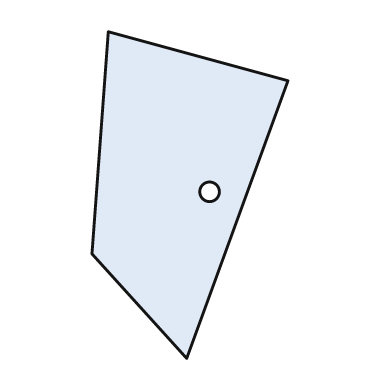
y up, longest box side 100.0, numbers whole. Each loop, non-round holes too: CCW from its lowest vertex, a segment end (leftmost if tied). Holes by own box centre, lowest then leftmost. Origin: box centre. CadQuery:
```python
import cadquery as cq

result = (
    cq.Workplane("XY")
    .moveTo(-1.0, -50.0)
    .lineTo(30.0, 35.0)
    .lineTo(-25.0, 50.0)
    .lineTo(-30.0, -18.0)
    .close()
    .moveTo(6.0, 1.0)
    .circle(3.0)
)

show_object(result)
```